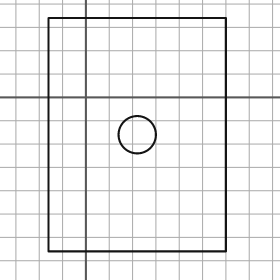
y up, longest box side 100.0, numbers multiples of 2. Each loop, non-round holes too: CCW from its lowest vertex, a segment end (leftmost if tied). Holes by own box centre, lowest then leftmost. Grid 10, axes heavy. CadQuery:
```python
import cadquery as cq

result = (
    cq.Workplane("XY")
    .moveTo(-16.0, -66.0)
    .lineTo(60.0, -66.0)
    .lineTo(60.0, 34.0)
    .lineTo(-16.0, 34.0)
    .close()
    .moveTo(22.0, -16.0)
    .circle(8.0)
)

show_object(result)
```